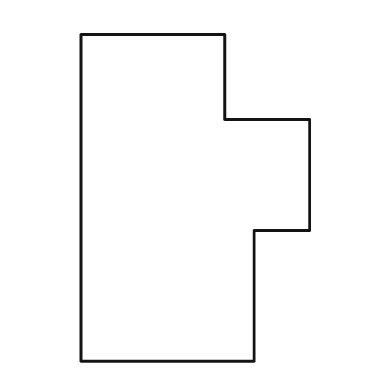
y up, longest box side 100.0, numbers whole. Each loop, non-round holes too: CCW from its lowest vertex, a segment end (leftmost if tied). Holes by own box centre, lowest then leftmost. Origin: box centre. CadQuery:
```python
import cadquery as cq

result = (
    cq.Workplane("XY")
    .moveTo(-35.0, -50.0)
    .lineTo(18.0, -50.0)
    .lineTo(18.0, -10.0)
    .lineTo(35.0, -10.0)
    .lineTo(35.0, 24.0)
    .lineTo(9.0, 24.0)
    .lineTo(9.0, 50.0)
    .lineTo(-35.0, 50.0)
    .close()
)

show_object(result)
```